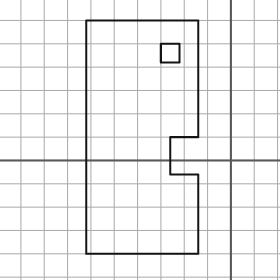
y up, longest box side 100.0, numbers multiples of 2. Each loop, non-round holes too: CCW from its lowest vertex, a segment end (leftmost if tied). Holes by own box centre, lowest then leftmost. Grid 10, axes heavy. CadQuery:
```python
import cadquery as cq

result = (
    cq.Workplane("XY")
    .moveTo(-62.0, -40.0)
    .lineTo(-14.0, -40.0)
    .lineTo(-14.0, -6.0)
    .lineTo(-26.0, -6.0)
    .lineTo(-26.0, 10.0)
    .lineTo(-14.0, 10.0)
    .lineTo(-14.0, 60.0)
    .lineTo(-62.0, 60.0)
    .close()
    .moveTo(-30.0, 42.0)
    .lineTo(-22.0, 42.0)
    .lineTo(-22.0, 50.0)
    .lineTo(-30.0, 50.0)
    .close()
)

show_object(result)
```